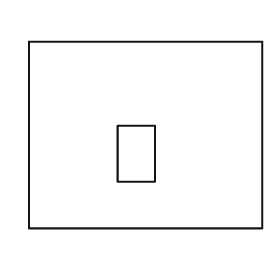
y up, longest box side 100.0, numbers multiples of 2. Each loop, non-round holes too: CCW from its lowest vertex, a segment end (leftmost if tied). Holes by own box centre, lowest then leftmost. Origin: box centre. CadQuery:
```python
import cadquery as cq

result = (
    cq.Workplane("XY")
    .moveTo(-50.0, -40.0)
    .lineTo(50.0, -40.0)
    .lineTo(50.0, 40.0)
    .lineTo(-50.0, 40.0)
    .close()
    .moveTo(-12.0, -20.0)
    .lineTo(4.0, -20.0)
    .lineTo(4.0, 4.0)
    .lineTo(-12.0, 4.0)
    .close()
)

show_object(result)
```